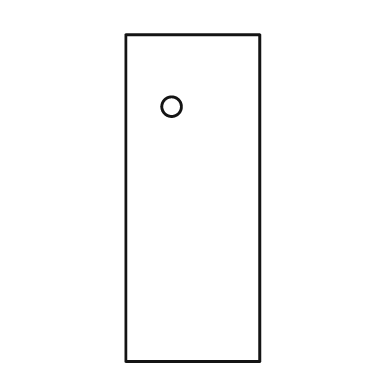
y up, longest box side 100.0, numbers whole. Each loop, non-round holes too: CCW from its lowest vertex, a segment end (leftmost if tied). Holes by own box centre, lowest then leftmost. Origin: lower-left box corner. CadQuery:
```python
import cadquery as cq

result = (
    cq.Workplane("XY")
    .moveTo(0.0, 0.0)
    .lineTo(41.0, 0.0)
    .lineTo(41.0, 100.0)
    .lineTo(0.0, 100.0)
    .close()
    .moveTo(14.0, 78.0)
    .circle(3.0)
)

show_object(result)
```